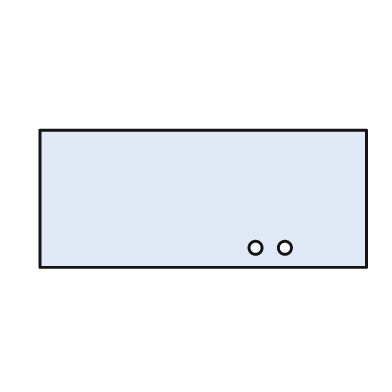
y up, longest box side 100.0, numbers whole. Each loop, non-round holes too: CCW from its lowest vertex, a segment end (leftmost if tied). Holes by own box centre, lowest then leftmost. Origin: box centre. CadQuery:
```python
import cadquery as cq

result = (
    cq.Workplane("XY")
    .moveTo(-50.0, -21.0)
    .lineTo(50.0, -21.0)
    .lineTo(50.0, 21.0)
    .lineTo(-50.0, 21.0)
    .close()
    .moveTo(16.0, -15.0)
    .circle(2.0)
    .moveTo(25.0, -15.0)
    .circle(2.0)
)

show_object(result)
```